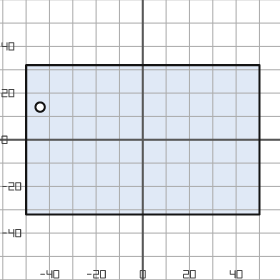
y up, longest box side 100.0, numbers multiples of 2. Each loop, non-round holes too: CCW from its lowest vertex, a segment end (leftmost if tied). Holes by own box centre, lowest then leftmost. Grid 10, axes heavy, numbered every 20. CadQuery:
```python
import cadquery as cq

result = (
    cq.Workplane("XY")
    .moveTo(-50.0, -32.0)
    .lineTo(50.0, -32.0)
    .lineTo(50.0, 32.0)
    .lineTo(-50.0, 32.0)
    .close()
    .moveTo(-44.0, 14.0)
    .circle(2.0)
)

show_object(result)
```